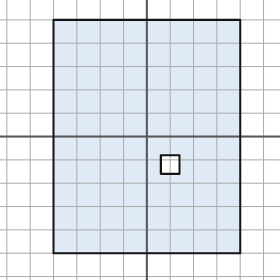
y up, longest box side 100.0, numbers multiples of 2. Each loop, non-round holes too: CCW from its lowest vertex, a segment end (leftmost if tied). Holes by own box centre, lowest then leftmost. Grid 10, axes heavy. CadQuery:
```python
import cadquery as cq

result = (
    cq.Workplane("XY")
    .moveTo(-40.0, -50.0)
    .lineTo(40.0, -50.0)
    .lineTo(40.0, 50.0)
    .lineTo(-40.0, 50.0)
    .close()
    .moveTo(6.0, -16.0)
    .lineTo(14.0, -16.0)
    .lineTo(14.0, -8.0)
    .lineTo(6.0, -8.0)
    .close()
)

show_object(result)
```